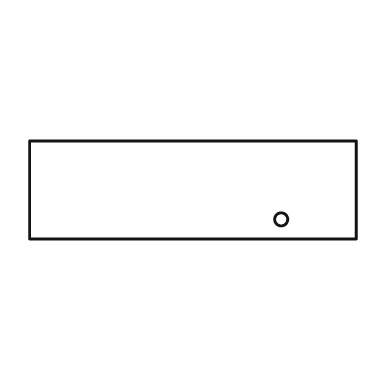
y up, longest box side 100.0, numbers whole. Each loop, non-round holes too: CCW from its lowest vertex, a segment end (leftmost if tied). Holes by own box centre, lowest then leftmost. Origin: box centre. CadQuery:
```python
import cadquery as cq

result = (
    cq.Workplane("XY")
    .moveTo(-50.0, -15.0)
    .lineTo(50.0, -15.0)
    .lineTo(50.0, 15.0)
    .lineTo(-50.0, 15.0)
    .close()
    .moveTo(27.0, -9.0)
    .circle(2.0)
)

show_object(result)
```